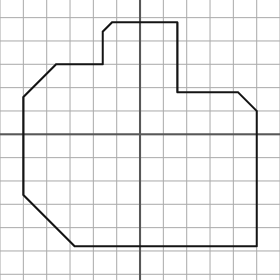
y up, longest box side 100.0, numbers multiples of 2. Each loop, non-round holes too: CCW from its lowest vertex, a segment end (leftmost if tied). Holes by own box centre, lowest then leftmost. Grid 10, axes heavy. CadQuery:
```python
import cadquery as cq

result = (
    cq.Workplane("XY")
    .moveTo(-28.0, -48.0)
    .lineTo(50.0, -48.0)
    .lineTo(50.0, 10.0)
    .lineTo(42.0, 18.0)
    .lineTo(16.0, 18.0)
    .lineTo(16.0, 48.0)
    .lineTo(-12.0, 48.0)
    .lineTo(-16.0, 44.0)
    .lineTo(-16.0, 30.0)
    .lineTo(-36.0, 30.0)
    .lineTo(-50.0, 16.0)
    .lineTo(-50.0, -26.0)
    .close()
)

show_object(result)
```